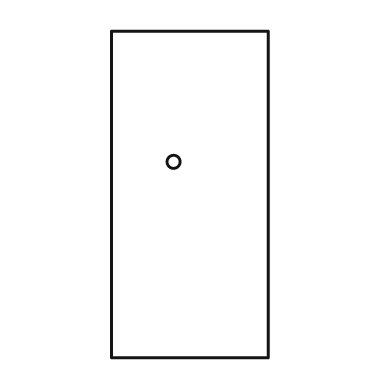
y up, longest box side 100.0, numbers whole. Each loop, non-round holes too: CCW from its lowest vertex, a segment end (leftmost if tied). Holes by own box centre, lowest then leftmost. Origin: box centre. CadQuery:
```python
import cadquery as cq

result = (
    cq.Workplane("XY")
    .moveTo(-24.0, -50.0)
    .lineTo(24.0, -50.0)
    .lineTo(24.0, 50.0)
    .lineTo(-24.0, 50.0)
    .close()
    .moveTo(-5.0, 10.0)
    .circle(2.0)
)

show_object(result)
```